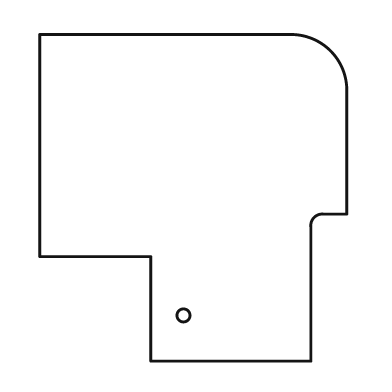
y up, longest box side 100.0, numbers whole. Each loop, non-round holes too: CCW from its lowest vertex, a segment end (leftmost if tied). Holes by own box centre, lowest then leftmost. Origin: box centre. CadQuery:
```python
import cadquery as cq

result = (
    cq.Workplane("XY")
    .moveTo(-13.0, -50.0)
    .lineTo(36.0, -50.0)
    .lineTo(36.0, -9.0)
    .threePointArc((37.0, -6.0), (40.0, -5.0))
    .lineTo(47.0, -5.0)
    .lineTo(47.0, 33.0)
    .threePointArc((42.0, 45.0), (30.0, 50.0))
    .lineTo(-47.0, 50.0)
    .lineTo(-47.0, -18.0)
    .lineTo(-13.0, -18.0)
    .close()
    .moveTo(-3.0, -36.0)
    .circle(2.0)
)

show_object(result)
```